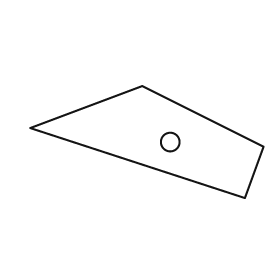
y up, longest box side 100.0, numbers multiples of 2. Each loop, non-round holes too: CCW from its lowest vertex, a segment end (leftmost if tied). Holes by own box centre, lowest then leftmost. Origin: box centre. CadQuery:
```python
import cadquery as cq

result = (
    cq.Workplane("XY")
    .moveTo(42.0, -24.0)
    .lineTo(50.0, -2.0)
    .lineTo(-2.0, 24.0)
    .lineTo(-50.0, 6.0)
    .close()
    .moveTo(10.0, 0.0)
    .circle(4.0)
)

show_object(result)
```